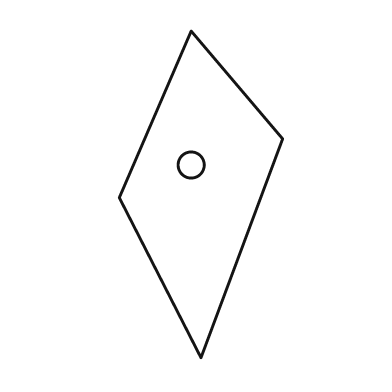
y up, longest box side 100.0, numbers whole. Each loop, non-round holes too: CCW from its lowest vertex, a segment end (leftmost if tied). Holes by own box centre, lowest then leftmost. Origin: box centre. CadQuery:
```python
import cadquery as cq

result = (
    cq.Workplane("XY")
    .moveTo(0.0, -50.0)
    .lineTo(25.0, 17.0)
    .lineTo(-3.0, 50.0)
    .lineTo(-25.0, -1.0)
    .close()
    .moveTo(-3.0, 9.0)
    .circle(4.0)
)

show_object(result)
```